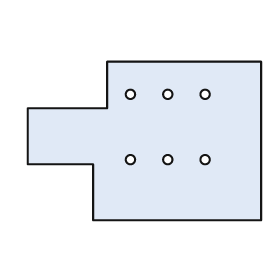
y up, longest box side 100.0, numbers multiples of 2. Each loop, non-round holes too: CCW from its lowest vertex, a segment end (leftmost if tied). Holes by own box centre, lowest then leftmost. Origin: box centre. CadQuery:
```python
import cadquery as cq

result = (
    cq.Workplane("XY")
    .moveTo(-22.0, -34.0)
    .lineTo(50.0, -34.0)
    .lineTo(50.0, 34.0)
    .lineTo(-16.0, 34.0)
    .lineTo(-16.0, 14.0)
    .lineTo(-50.0, 14.0)
    .lineTo(-50.0, -10.0)
    .lineTo(-22.0, -10.0)
    .close()
    .moveTo(-6.0, -8.0)
    .circle(2.0)
    .moveTo(10.0, -8.0)
    .circle(2.0)
    .moveTo(26.0, -8.0)
    .circle(2.0)
    .moveTo(-6.0, 20.0)
    .circle(2.0)
    .moveTo(10.0, 20.0)
    .circle(2.0)
    .moveTo(26.0, 20.0)
    .circle(2.0)
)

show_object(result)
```